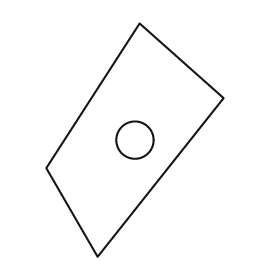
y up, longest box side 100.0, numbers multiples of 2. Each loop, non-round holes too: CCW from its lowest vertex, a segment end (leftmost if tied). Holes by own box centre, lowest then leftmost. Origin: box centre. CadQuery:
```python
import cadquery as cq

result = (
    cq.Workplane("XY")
    .moveTo(-16.0, -50.0)
    .lineTo(38.0, 18.0)
    .lineTo(2.0, 50.0)
    .lineTo(-38.0, -12.0)
    .close()
    .moveTo(0.0, 0.0)
    .circle(8.0)
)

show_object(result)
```